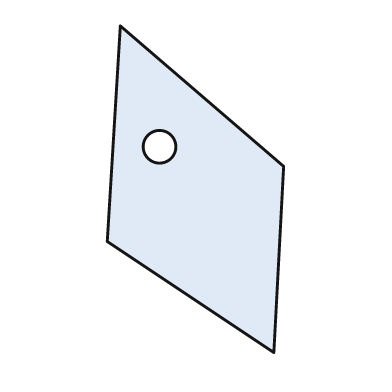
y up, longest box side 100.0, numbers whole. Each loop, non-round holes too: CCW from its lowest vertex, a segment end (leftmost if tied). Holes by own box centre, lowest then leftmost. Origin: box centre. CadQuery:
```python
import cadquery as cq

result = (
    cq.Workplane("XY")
    .moveTo(24.0, -50.0)
    .lineTo(27.0, 7.0)
    .lineTo(-23.0, 50.0)
    .lineTo(-27.0, -16.0)
    .close()
    .moveTo(-11.0, 13.0)
    .circle(5.0)
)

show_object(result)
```